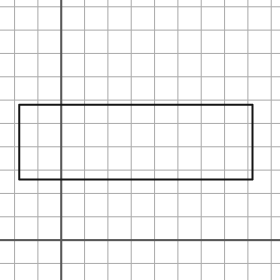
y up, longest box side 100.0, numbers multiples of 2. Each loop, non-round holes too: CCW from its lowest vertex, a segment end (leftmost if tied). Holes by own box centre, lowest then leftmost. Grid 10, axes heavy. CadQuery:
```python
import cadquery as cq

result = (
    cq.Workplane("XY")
    .moveTo(-18.0, 26.0)
    .lineTo(82.0, 26.0)
    .lineTo(82.0, 58.0)
    .lineTo(-18.0, 58.0)
    .close()
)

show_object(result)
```